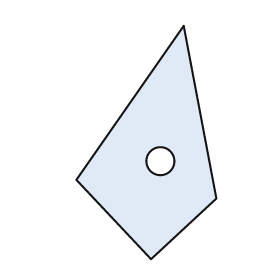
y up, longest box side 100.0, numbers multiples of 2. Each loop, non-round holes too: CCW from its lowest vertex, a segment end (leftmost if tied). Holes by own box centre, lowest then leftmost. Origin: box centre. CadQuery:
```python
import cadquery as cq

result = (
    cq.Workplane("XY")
    .moveTo(2.0, -50.0)
    .lineTo(30.0, -24.0)
    .lineTo(16.0, 50.0)
    .lineTo(-30.0, -16.0)
    .close()
    .moveTo(6.0, -8.0)
    .circle(6.0)
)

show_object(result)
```